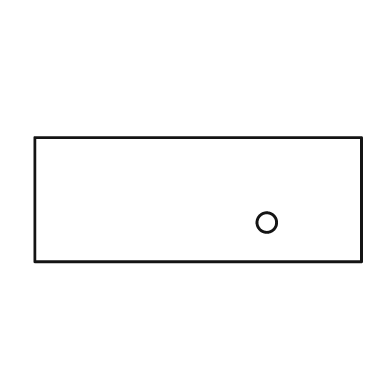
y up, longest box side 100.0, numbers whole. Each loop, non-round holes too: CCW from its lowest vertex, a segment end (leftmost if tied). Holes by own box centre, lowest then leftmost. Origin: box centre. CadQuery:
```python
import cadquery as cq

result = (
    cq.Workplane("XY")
    .moveTo(-50.0, -19.0)
    .lineTo(50.0, -19.0)
    .lineTo(50.0, 19.0)
    .lineTo(-50.0, 19.0)
    .close()
    .moveTo(21.0, -7.0)
    .circle(3.0)
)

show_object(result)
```